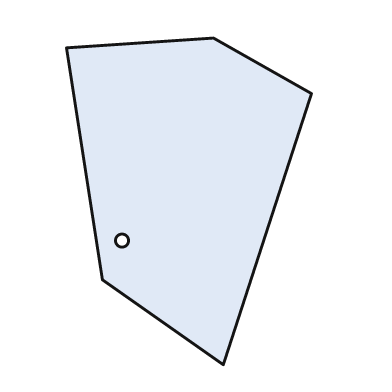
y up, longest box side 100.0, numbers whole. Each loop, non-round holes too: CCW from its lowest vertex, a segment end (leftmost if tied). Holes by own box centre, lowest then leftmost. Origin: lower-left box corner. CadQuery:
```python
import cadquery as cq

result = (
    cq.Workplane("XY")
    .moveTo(48.0, 0.0)
    .lineTo(75.0, 83.0)
    .lineTo(45.0, 100.0)
    .lineTo(0.0, 97.0)
    .lineTo(11.0, 26.0)
    .close()
    .moveTo(17.0, 38.0)
    .circle(2.0)
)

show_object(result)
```